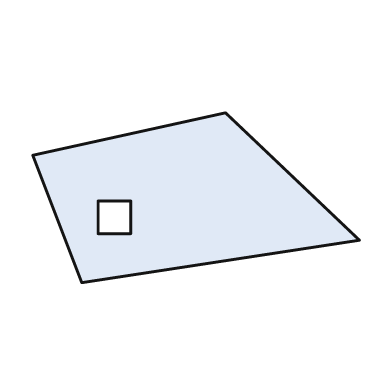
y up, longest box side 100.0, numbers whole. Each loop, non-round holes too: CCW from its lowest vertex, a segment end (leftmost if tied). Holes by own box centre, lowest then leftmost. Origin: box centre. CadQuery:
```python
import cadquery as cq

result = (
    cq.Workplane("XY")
    .moveTo(-35.0, -26.0)
    .lineTo(50.0, -13.0)
    .lineTo(9.0, 26.0)
    .lineTo(-50.0, 13.0)
    .close()
    .moveTo(-30.0, -11.0)
    .lineTo(-20.0, -11.0)
    .lineTo(-20.0, -1.0)
    .lineTo(-30.0, -1.0)
    .close()
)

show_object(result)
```